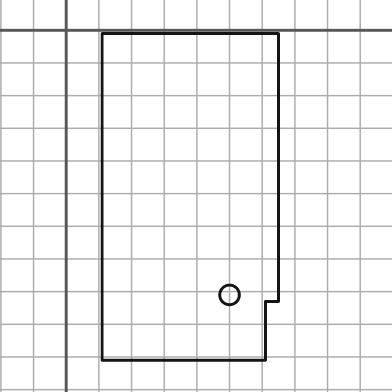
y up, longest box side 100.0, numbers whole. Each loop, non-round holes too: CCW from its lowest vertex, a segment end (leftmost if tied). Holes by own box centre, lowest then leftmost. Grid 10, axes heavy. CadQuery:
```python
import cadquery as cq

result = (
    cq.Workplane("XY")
    .moveTo(11.0, -101.0)
    .lineTo(61.0, -101.0)
    .lineTo(61.0, -83.0)
    .lineTo(65.0, -83.0)
    .lineTo(65.0, -1.0)
    .lineTo(11.0, -1.0)
    .close()
    .moveTo(50.0, -81.0)
    .circle(3.0)
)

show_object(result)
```